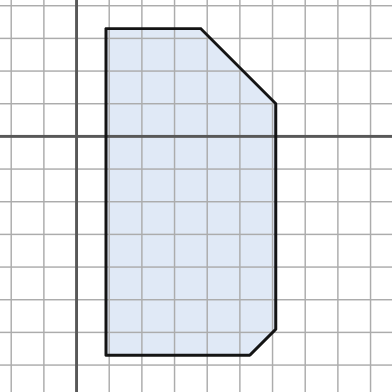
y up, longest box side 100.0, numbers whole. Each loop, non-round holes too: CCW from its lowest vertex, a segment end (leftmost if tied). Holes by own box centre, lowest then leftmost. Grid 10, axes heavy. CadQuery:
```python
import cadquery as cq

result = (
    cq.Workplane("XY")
    .moveTo(9.0, -67.0)
    .lineTo(53.0, -67.0)
    .lineTo(61.0, -59.0)
    .lineTo(61.0, 10.0)
    .lineTo(38.0, 33.0)
    .lineTo(9.0, 33.0)
    .close()
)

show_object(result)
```